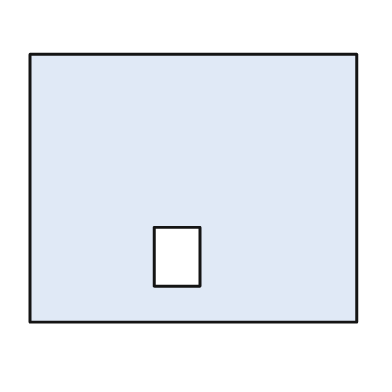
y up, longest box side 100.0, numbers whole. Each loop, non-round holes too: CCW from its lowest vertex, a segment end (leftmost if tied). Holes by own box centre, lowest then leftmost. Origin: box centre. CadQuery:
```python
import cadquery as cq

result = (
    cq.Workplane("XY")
    .moveTo(-50.0, -41.0)
    .lineTo(50.0, -41.0)
    .lineTo(50.0, 41.0)
    .lineTo(-50.0, 41.0)
    .close()
    .moveTo(-12.0, -30.0)
    .lineTo(2.0, -30.0)
    .lineTo(2.0, -12.0)
    .lineTo(-12.0, -12.0)
    .close()
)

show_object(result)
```